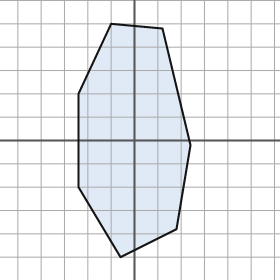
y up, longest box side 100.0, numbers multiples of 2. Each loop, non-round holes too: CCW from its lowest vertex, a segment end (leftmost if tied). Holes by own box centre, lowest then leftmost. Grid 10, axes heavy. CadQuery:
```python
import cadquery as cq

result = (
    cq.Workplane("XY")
    .moveTo(-6.0, -50.0)
    .lineTo(18.0, -38.0)
    .lineTo(24.0, -2.0)
    .lineTo(12.0, 48.0)
    .lineTo(-10.0, 50.0)
    .lineTo(-24.0, 20.0)
    .lineTo(-24.0, -20.0)
    .close()
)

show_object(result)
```